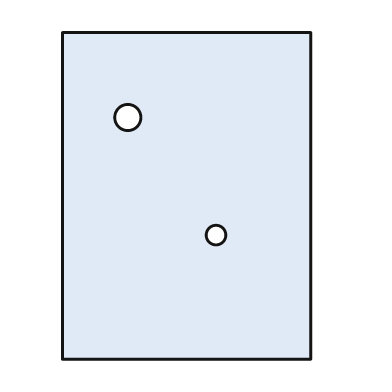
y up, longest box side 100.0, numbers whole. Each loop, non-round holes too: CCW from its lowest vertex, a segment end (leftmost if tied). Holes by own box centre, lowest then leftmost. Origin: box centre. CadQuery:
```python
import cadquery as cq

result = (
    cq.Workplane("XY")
    .moveTo(-38.0, -50.0)
    .lineTo(38.0, -50.0)
    .lineTo(38.0, 50.0)
    .lineTo(-38.0, 50.0)
    .close()
    .moveTo(9.0, -12.0)
    .circle(3.0)
    .moveTo(-18.0, 24.0)
    .circle(4.0)
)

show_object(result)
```